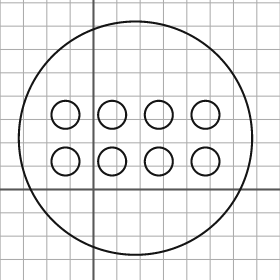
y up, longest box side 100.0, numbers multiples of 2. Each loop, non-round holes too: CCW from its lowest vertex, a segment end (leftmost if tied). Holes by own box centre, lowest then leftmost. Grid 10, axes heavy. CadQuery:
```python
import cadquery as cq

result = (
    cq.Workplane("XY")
    .moveTo(18.0, 22.0)
    .circle(50.0)
    .moveTo(-12.0, 12.0)
    .circle(6.0)
    .moveTo(8.0, 12.0)
    .circle(6.0)
    .moveTo(28.0, 12.0)
    .circle(6.0)
    .moveTo(48.0, 12.0)
    .circle(6.0)
    .moveTo(-12.0, 32.0)
    .circle(6.0)
    .moveTo(8.0, 32.0)
    .circle(6.0)
    .moveTo(28.0, 32.0)
    .circle(6.0)
    .moveTo(48.0, 32.0)
    .circle(6.0)
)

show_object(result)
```